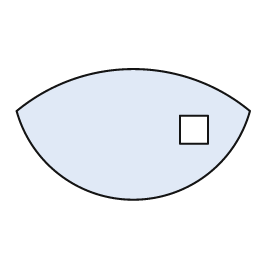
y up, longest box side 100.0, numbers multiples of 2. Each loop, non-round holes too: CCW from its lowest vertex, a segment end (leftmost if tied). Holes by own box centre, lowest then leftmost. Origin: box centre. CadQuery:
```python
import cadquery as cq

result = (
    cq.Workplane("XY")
    .moveTo(-50.0, 10.0)
    .threePointArc((0.0, -28.0), (50.0, 10.0))
    .threePointArc((0.0, 28.0), (-50.0, 10.0))
    .close()
    .moveTo(20.0, -4.0)
    .lineTo(32.0, -4.0)
    .lineTo(32.0, 8.0)
    .lineTo(20.0, 8.0)
    .close()
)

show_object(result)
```